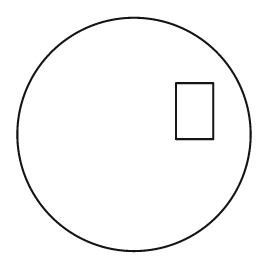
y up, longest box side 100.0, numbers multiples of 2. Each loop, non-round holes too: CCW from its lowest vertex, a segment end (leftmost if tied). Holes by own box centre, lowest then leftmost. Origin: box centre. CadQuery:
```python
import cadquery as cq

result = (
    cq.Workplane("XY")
    .moveTo(0.0, 0.0)
    .circle(50.0)
    .moveTo(18.0, -2.0)
    .lineTo(34.0, -2.0)
    .lineTo(34.0, 22.0)
    .lineTo(18.0, 22.0)
    .close()
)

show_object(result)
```